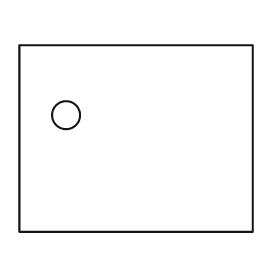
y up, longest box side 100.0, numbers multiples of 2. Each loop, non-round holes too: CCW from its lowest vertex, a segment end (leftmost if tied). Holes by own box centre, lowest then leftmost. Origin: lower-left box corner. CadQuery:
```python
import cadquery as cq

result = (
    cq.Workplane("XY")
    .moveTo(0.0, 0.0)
    .lineTo(100.0, 0.0)
    .lineTo(100.0, 80.0)
    .lineTo(0.0, 80.0)
    .close()
    .moveTo(20.0, 50.0)
    .circle(6.0)
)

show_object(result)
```